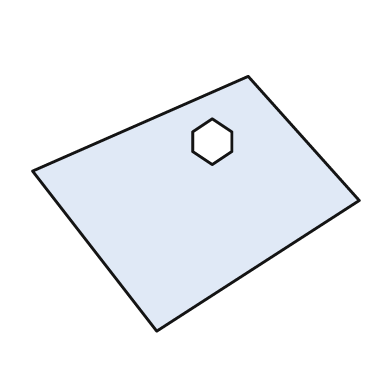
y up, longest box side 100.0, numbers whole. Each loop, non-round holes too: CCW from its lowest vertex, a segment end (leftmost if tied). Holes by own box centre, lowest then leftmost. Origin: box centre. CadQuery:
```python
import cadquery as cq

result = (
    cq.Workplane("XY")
    .moveTo(-12.0, -39.0)
    .lineTo(50.0, 1.0)
    .lineTo(16.0, 39.0)
    .lineTo(-50.0, 10.0)
    .close()
    .moveTo(5.0, 12.0)
    .lineTo(11.0, 16.0)
    .lineTo(11.0, 22.0)
    .lineTo(5.0, 26.0)
    .lineTo(-1.0, 22.0)
    .lineTo(-1.0, 16.0)
    .close()
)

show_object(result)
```